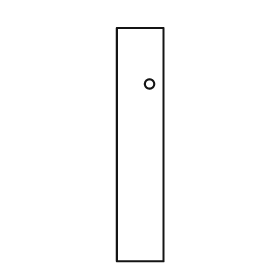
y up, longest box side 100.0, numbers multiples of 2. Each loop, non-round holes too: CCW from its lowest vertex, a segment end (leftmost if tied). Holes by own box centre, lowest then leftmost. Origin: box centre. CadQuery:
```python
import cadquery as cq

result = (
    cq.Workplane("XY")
    .moveTo(-10.0, -50.0)
    .lineTo(10.0, -50.0)
    .lineTo(10.0, 50.0)
    .lineTo(-10.0, 50.0)
    .close()
    .moveTo(4.0, 26.0)
    .circle(2.0)
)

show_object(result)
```